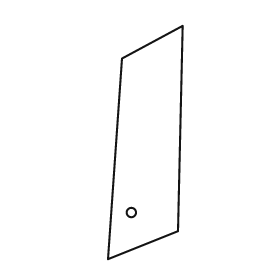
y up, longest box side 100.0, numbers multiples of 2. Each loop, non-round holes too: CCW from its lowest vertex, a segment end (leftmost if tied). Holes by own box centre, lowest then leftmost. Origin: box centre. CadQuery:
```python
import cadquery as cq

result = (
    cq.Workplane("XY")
    .moveTo(-16.0, -50.0)
    .lineTo(14.0, -38.0)
    .lineTo(16.0, 50.0)
    .lineTo(-10.0, 36.0)
    .close()
    .moveTo(-6.0, -30.0)
    .circle(2.0)
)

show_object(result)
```